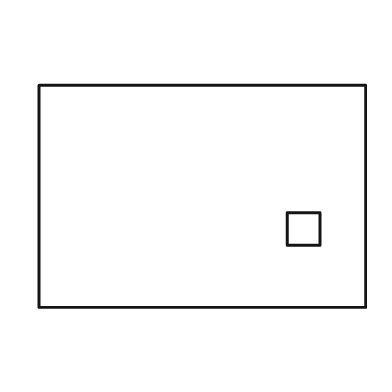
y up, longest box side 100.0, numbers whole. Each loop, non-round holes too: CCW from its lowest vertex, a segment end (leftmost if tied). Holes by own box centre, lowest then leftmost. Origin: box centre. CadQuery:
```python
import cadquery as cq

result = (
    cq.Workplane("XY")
    .moveTo(-50.0, -34.0)
    .lineTo(50.0, -34.0)
    .lineTo(50.0, 34.0)
    .lineTo(-50.0, 34.0)
    .close()
    .moveTo(26.0, -15.0)
    .lineTo(36.0, -15.0)
    .lineTo(36.0, -5.0)
    .lineTo(26.0, -5.0)
    .close()
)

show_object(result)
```